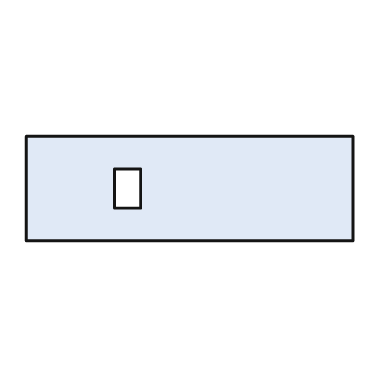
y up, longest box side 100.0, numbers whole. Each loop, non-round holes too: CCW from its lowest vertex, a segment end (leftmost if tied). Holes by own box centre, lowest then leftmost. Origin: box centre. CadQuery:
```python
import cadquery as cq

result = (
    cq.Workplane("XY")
    .moveTo(-50.0, -16.0)
    .lineTo(50.0, -16.0)
    .lineTo(50.0, 16.0)
    .lineTo(-50.0, 16.0)
    .close()
    .moveTo(-23.0, -6.0)
    .lineTo(-15.0, -6.0)
    .lineTo(-15.0, 6.0)
    .lineTo(-23.0, 6.0)
    .close()
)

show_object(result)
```